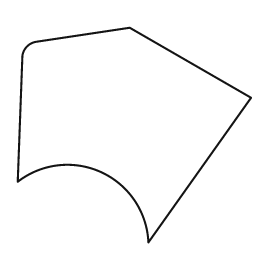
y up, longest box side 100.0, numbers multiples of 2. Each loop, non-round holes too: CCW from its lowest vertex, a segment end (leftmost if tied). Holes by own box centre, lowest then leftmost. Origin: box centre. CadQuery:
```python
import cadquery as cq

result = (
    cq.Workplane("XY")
    .moveTo(6.0, -46.0)
    .lineTo(50.0, 16.0)
    .lineTo(-2.0, 46.0)
    .lineTo(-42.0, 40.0)
    .threePointArc((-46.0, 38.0), (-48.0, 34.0))
    .lineTo(-50.0, -20.0)
    .threePointArc((-14.0, -16.0), (6.0, -46.0))
    .close()
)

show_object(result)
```